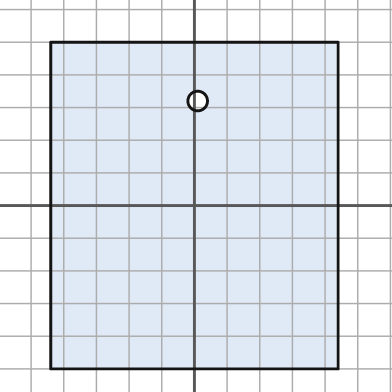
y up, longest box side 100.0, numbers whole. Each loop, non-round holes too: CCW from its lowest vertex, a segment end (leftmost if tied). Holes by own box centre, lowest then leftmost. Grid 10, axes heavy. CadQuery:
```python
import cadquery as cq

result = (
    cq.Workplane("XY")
    .moveTo(-44.0, -50.0)
    .lineTo(44.0, -50.0)
    .lineTo(44.0, 50.0)
    .lineTo(-44.0, 50.0)
    .close()
    .moveTo(1.0, 32.0)
    .circle(3.0)
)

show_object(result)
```